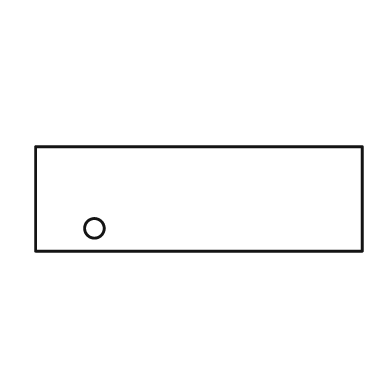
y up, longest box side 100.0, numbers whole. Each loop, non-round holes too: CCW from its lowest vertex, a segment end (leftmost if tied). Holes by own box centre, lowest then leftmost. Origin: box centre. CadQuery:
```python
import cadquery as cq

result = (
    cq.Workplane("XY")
    .moveTo(-50.0, -16.0)
    .lineTo(50.0, -16.0)
    .lineTo(50.0, 16.0)
    .lineTo(-50.0, 16.0)
    .close()
    .moveTo(-32.0, -9.0)
    .circle(3.0)
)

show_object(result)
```